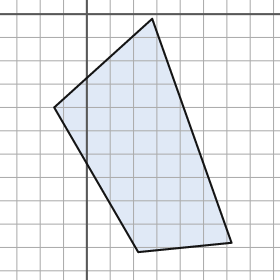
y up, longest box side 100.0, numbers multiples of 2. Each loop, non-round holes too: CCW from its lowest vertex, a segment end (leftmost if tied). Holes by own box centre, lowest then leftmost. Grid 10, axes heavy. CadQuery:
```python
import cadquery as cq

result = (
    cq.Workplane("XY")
    .moveTo(22.0, -102.0)
    .lineTo(62.0, -98.0)
    .lineTo(28.0, -2.0)
    .lineTo(-14.0, -40.0)
    .close()
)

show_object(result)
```